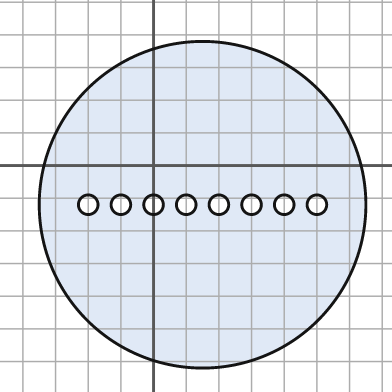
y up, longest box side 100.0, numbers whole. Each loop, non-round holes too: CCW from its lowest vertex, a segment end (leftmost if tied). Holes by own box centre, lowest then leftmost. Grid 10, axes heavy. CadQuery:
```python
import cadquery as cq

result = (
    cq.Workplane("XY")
    .moveTo(15.0, -12.0)
    .circle(50.0)
    .moveTo(-20.0, -12.0)
    .circle(3.0)
    .moveTo(-10.0, -12.0)
    .circle(3.0)
    .moveTo(0.0, -12.0)
    .circle(3.0)
    .moveTo(10.0, -12.0)
    .circle(3.0)
    .moveTo(20.0, -12.0)
    .circle(3.0)
    .moveTo(30.0, -12.0)
    .circle(3.0)
    .moveTo(40.0, -12.0)
    .circle(3.0)
    .moveTo(50.0, -12.0)
    .circle(3.0)
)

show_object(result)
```